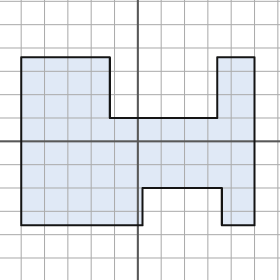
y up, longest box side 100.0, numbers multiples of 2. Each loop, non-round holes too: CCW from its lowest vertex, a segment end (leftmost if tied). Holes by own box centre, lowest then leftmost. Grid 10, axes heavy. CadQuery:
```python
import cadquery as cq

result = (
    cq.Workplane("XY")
    .moveTo(-50.0, -36.0)
    .lineTo(2.0, -36.0)
    .lineTo(2.0, -20.0)
    .lineTo(36.0, -20.0)
    .lineTo(36.0, -36.0)
    .lineTo(50.0, -36.0)
    .lineTo(50.0, 36.0)
    .lineTo(34.0, 36.0)
    .lineTo(34.0, 10.0)
    .lineTo(-12.0, 10.0)
    .lineTo(-12.0, 36.0)
    .lineTo(-50.0, 36.0)
    .close()
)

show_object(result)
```